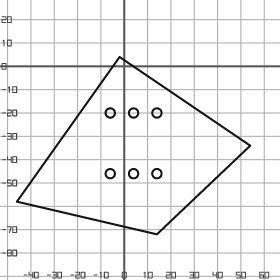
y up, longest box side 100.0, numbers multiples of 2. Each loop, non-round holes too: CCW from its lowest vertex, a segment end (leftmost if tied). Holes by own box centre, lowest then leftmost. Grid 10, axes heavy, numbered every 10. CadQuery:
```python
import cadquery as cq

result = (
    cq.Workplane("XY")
    .moveTo(14.0, -72.0)
    .lineTo(54.0, -34.0)
    .lineTo(-2.0, 4.0)
    .lineTo(-46.0, -58.0)
    .close()
    .moveTo(-6.0, -46.0)
    .circle(2.0)
    .moveTo(4.0, -46.0)
    .circle(2.0)
    .moveTo(14.0, -46.0)
    .circle(2.0)
    .moveTo(-6.0, -20.0)
    .circle(2.0)
    .moveTo(4.0, -20.0)
    .circle(2.0)
    .moveTo(14.0, -20.0)
    .circle(2.0)
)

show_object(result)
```